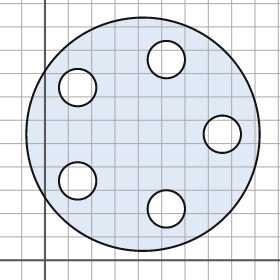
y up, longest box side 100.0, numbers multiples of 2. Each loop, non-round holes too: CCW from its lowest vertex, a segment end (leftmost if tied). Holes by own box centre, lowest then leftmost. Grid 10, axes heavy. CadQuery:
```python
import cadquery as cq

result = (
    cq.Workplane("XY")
    .moveTo(42.0, 54.0)
    .circle(50.0)
    .moveTo(52.0, 22.0)
    .circle(8.0)
    .moveTo(14.0, 34.0)
    .circle(8.0)
    .moveTo(76.0, 54.0)
    .circle(8.0)
    .moveTo(14.0, 74.0)
    .circle(8.0)
    .moveTo(52.0, 86.0)
    .circle(8.0)
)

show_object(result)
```